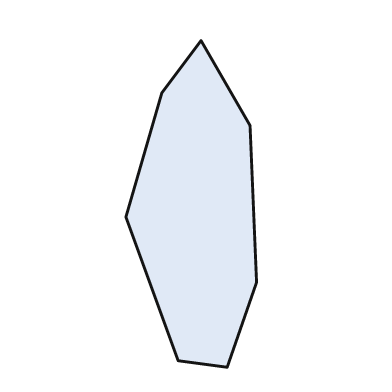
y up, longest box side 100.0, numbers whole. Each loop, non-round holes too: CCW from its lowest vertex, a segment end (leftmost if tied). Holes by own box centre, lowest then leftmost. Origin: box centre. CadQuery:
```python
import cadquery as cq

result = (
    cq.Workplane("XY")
    .moveTo(11.0, -50.0)
    .lineTo(20.0, -24.0)
    .lineTo(18.0, 24.0)
    .lineTo(3.0, 50.0)
    .lineTo(-9.0, 34.0)
    .lineTo(-20.0, -4.0)
    .lineTo(-4.0, -48.0)
    .close()
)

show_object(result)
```